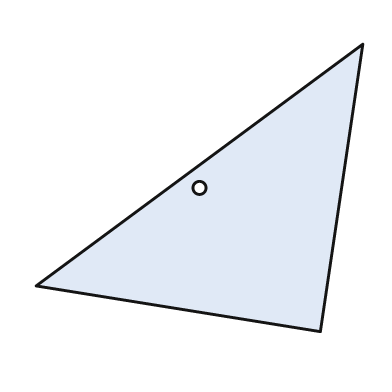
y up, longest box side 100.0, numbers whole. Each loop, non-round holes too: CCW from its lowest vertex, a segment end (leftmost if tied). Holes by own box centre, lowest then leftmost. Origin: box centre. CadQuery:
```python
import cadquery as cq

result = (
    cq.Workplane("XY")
    .moveTo(37.0, -44.0)
    .lineTo(50.0, 44.0)
    .lineTo(-50.0, -30.0)
    .close()
    .moveTo(0.0, 0.0)
    .circle(2.0)
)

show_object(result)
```